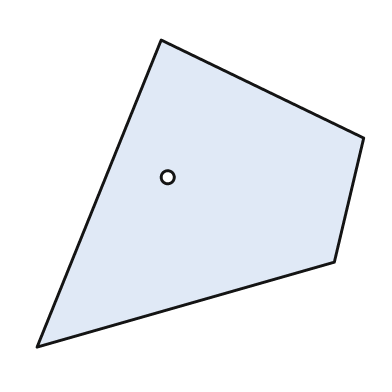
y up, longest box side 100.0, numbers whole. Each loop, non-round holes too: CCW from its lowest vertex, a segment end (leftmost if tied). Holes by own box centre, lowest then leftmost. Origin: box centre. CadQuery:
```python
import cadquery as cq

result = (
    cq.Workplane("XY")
    .moveTo(-50.0, -47.0)
    .lineTo(41.0, -21.0)
    .lineTo(50.0, 17.0)
    .lineTo(-12.0, 47.0)
    .close()
    .moveTo(-10.0, 5.0)
    .circle(2.0)
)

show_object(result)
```